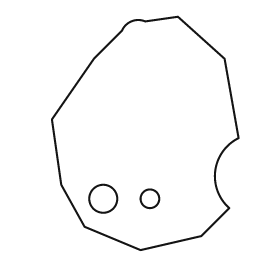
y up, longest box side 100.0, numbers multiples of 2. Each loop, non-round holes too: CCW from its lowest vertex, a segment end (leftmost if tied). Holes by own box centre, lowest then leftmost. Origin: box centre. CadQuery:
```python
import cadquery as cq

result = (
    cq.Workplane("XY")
    .moveTo(-2.0, -50.0)
    .lineTo(24.0, -44.0)
    .lineTo(36.0, -32.0)
    .threePointArc((30.0, -16.0), (40.0, -2.0))
    .lineTo(34.0, 32.0)
    .lineTo(14.0, 50.0)
    .lineTo(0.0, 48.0)
    .threePointArc((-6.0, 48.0), (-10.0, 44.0))
    .lineTo(-22.0, 32.0)
    .lineTo(-40.0, 6.0)
    .lineTo(-36.0, -22.0)
    .lineTo(-26.0, -40.0)
    .close()
    .moveTo(-18.0, -28.0)
    .circle(6.0)
    .moveTo(2.0, -28.0)
    .circle(4.0)
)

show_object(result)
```